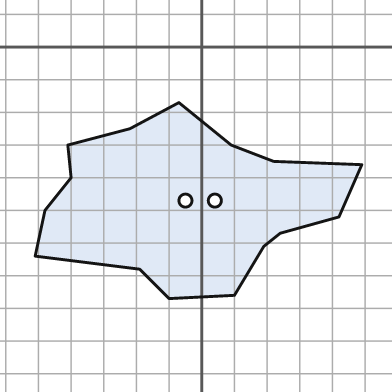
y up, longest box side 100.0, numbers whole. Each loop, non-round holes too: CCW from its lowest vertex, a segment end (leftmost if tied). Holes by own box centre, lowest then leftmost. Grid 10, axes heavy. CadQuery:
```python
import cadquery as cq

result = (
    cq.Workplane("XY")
    .moveTo(-10.0, -77.0)
    .lineTo(10.0, -76.0)
    .lineTo(19.0, -61.0)
    .lineTo(24.0, -57.0)
    .lineTo(42.0, -52.0)
    .lineTo(49.0, -36.0)
    .lineTo(22.0, -35.0)
    .lineTo(9.0, -30.0)
    .lineTo(-7.0, -17.0)
    .lineTo(-22.0, -25.0)
    .lineTo(-41.0, -30.0)
    .lineTo(-40.0, -40.0)
    .lineTo(-48.0, -50.0)
    .lineTo(-51.0, -64.0)
    .lineTo(-19.0, -68.0)
    .close()
    .moveTo(-5.0, -47.0)
    .circle(2.0)
    .moveTo(4.0, -47.0)
    .circle(2.0)
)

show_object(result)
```